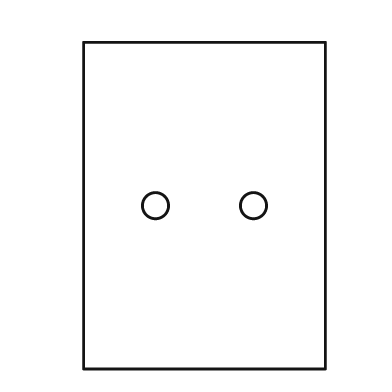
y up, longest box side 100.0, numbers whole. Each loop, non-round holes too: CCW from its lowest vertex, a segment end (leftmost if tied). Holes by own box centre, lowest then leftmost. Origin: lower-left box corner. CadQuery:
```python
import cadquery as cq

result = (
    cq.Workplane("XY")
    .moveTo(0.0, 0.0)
    .lineTo(74.0, 0.0)
    .lineTo(74.0, 100.0)
    .lineTo(0.0, 100.0)
    .close()
    .moveTo(22.0, 50.0)
    .circle(4.0)
    .moveTo(52.0, 50.0)
    .circle(4.0)
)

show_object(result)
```